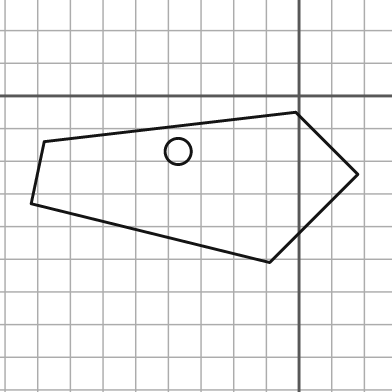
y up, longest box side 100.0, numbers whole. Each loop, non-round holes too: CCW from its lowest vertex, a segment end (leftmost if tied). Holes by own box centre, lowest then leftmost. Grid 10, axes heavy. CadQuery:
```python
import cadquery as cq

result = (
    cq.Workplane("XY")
    .moveTo(-9.0, -51.0)
    .lineTo(18.0, -24.0)
    .lineTo(-1.0, -5.0)
    .lineTo(-78.0, -14.0)
    .lineTo(-82.0, -33.0)
    .close()
    .moveTo(-37.0, -17.0)
    .circle(4.0)
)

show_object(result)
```